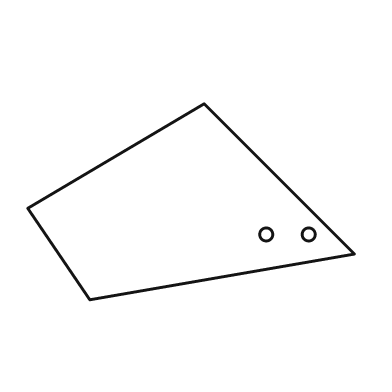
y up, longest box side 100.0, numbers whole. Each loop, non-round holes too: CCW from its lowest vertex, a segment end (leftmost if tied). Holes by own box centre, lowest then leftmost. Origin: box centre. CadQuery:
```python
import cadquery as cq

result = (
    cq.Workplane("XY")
    .moveTo(-31.0, -30.0)
    .lineTo(50.0, -16.0)
    .lineTo(4.0, 30.0)
    .lineTo(-50.0, -2.0)
    .close()
    .moveTo(23.0, -10.0)
    .circle(2.0)
    .moveTo(36.0, -10.0)
    .circle(2.0)
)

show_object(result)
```